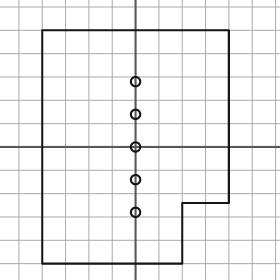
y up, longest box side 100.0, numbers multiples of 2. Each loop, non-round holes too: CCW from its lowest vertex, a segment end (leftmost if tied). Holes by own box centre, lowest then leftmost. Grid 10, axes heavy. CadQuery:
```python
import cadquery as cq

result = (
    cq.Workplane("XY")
    .moveTo(-40.0, -50.0)
    .lineTo(20.0, -50.0)
    .lineTo(20.0, -24.0)
    .lineTo(40.0, -24.0)
    .lineTo(40.0, 50.0)
    .lineTo(-40.0, 50.0)
    .close()
    .moveTo(0.0, -28.0)
    .circle(2.0)
    .moveTo(0.0, -14.0)
    .circle(2.0)
    .moveTo(0.0, 0.0)
    .circle(2.0)
    .moveTo(0.0, 14.0)
    .circle(2.0)
    .moveTo(0.0, 28.0)
    .circle(2.0)
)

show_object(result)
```